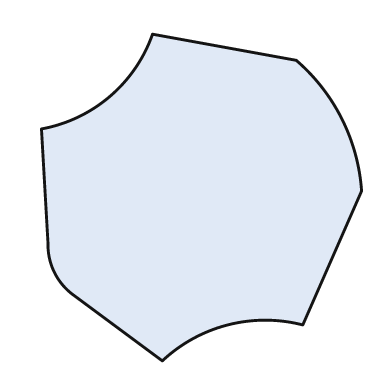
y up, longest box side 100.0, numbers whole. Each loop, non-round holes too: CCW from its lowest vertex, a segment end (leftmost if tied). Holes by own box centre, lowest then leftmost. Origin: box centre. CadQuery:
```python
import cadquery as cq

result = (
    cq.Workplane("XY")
    .moveTo(-12.0, -50.0)
    .threePointArc((8.0, -39.0), (31.0, -39.0))
    .lineTo(49.0, 2.0)
    .threePointArc((43.0, 24.0), (29.0, 42.0))
    .lineTo(-15.0, 50.0)
    .threePointArc((-28.0, 31.0), (-49.0, 21.0))
    .lineTo(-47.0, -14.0)
    .threePointArc((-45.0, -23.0), (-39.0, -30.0))
    .close()
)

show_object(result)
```